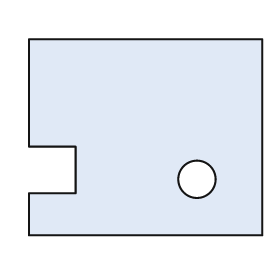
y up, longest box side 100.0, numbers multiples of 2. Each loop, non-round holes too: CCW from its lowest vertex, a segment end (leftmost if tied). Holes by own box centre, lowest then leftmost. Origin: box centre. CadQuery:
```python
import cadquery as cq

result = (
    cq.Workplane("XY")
    .moveTo(-50.0, -42.0)
    .lineTo(50.0, -42.0)
    .lineTo(50.0, 42.0)
    .lineTo(-50.0, 42.0)
    .lineTo(-50.0, -4.0)
    .lineTo(-30.0, -4.0)
    .lineTo(-30.0, -24.0)
    .lineTo(-50.0, -24.0)
    .close()
    .moveTo(22.0, -18.0)
    .circle(8.0)
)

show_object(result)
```